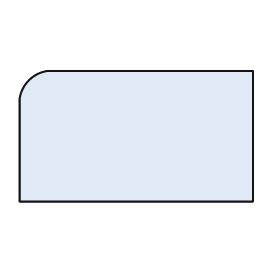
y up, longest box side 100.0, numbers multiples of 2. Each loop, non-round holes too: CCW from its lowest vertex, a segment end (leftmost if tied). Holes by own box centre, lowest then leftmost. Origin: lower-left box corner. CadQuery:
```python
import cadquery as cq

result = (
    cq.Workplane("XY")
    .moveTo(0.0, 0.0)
    .lineTo(100.0, 0.0)
    .lineTo(100.0, 56.0)
    .lineTo(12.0, 56.0)
    .threePointArc((4.0, 52.0), (0.0, 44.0))
    .close()
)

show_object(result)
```